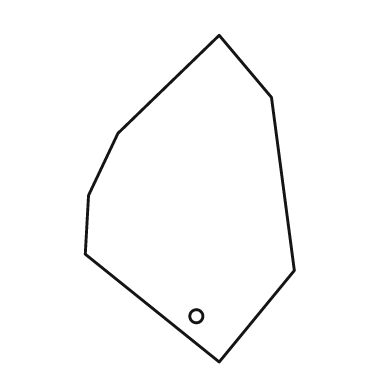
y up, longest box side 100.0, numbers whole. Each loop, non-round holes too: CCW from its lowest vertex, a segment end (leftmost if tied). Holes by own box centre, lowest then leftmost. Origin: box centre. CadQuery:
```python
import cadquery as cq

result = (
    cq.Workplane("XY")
    .moveTo(9.0, -50.0)
    .lineTo(32.0, -22.0)
    .lineTo(25.0, 31.0)
    .lineTo(9.0, 50.0)
    .lineTo(-22.0, 20.0)
    .lineTo(-31.0, 1.0)
    .lineTo(-32.0, -17.0)
    .close()
    .moveTo(2.0, -36.0)
    .circle(2.0)
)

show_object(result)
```